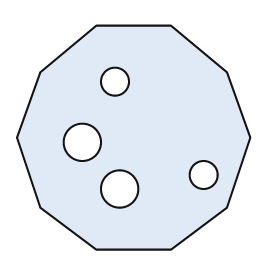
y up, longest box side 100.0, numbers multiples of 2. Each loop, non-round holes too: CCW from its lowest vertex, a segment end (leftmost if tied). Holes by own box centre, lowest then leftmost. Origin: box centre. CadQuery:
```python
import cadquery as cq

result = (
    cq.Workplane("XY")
    .moveTo(-16.0, -48.0)
    .lineTo(16.0, -48.0)
    .lineTo(40.0, -30.0)
    .lineTo(50.0, 0.0)
    .lineTo(40.0, 28.0)
    .lineTo(16.0, 48.0)
    .lineTo(-16.0, 48.0)
    .lineTo(-40.0, 28.0)
    .lineTo(-50.0, 0.0)
    .lineTo(-40.0, -30.0)
    .close()
    .moveTo(-6.0, -22.0)
    .circle(8.0)
    .moveTo(30.0, -16.0)
    .circle(6.0)
    .moveTo(-22.0, -2.0)
    .circle(8.0)
    .moveTo(-8.0, 24.0)
    .circle(6.0)
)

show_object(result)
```